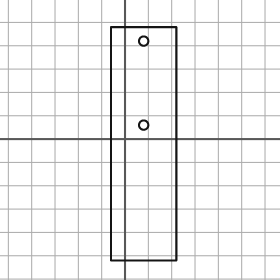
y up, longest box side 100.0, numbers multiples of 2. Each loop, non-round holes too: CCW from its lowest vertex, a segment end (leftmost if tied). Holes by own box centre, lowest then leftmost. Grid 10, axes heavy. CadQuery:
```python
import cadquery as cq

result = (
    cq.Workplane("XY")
    .moveTo(-6.0, -52.0)
    .lineTo(22.0, -52.0)
    .lineTo(22.0, 48.0)
    .lineTo(-6.0, 48.0)
    .close()
    .moveTo(8.0, 6.0)
    .circle(2.0)
    .moveTo(8.0, 42.0)
    .circle(2.0)
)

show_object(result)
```